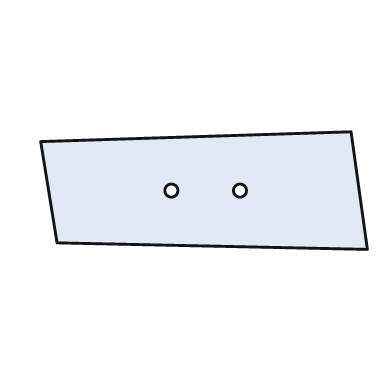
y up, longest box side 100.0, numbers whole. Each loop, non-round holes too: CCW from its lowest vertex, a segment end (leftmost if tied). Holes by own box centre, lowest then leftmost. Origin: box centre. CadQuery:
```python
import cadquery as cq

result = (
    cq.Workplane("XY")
    .moveTo(50.0, -18.0)
    .lineTo(45.0, 18.0)
    .lineTo(-50.0, 15.0)
    .lineTo(-45.0, -16.0)
    .close()
    .moveTo(-10.0, 0.0)
    .circle(2.0)
    .moveTo(11.0, 0.0)
    .circle(2.0)
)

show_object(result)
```